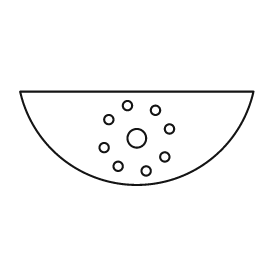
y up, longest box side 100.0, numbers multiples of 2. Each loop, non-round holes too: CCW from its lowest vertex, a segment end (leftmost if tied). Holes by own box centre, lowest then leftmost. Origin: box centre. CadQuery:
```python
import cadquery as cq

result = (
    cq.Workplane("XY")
    .moveTo(-50.0, 20.0)
    .threePointArc((0.0, -20.0), (50.0, 20.0))
    .close()
    .moveTo(4.0, -14.0)
    .circle(2.0)
    .moveTo(-8.0, -12.0)
    .circle(2.0)
    .moveTo(12.0, -8.0)
    .circle(2.0)
    .moveTo(-14.0, -4.0)
    .circle(2.0)
    .moveTo(0.0, 0.0)
    .circle(4.0)
    .moveTo(14.0, 4.0)
    .circle(2.0)
    .moveTo(-12.0, 8.0)
    .circle(2.0)
    .moveTo(8.0, 12.0)
    .circle(2.0)
    .moveTo(-4.0, 14.0)
    .circle(2.0)
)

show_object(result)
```